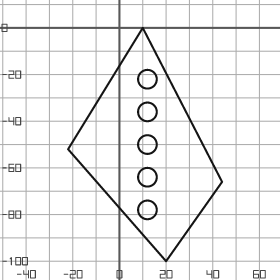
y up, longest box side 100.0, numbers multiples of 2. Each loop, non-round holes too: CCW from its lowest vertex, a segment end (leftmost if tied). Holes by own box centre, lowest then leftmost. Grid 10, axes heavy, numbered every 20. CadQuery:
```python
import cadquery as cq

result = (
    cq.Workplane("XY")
    .moveTo(20.0, -100.0)
    .lineTo(44.0, -66.0)
    .lineTo(10.0, 0.0)
    .lineTo(-22.0, -52.0)
    .close()
    .moveTo(12.0, -78.0)
    .circle(4.0)
    .moveTo(12.0, -64.0)
    .circle(4.0)
    .moveTo(12.0, -50.0)
    .circle(4.0)
    .moveTo(12.0, -36.0)
    .circle(4.0)
    .moveTo(12.0, -22.0)
    .circle(4.0)
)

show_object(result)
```